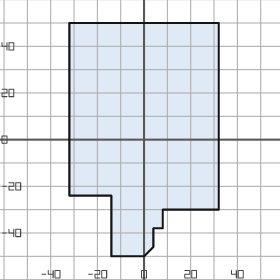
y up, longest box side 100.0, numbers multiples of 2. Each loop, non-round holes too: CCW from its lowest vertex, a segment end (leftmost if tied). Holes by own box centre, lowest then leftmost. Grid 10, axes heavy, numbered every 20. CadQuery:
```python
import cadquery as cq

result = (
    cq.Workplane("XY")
    .moveTo(-14.0, -50.0)
    .lineTo(0.0, -50.0)
    .lineTo(4.0, -46.0)
    .lineTo(4.0, -38.0)
    .lineTo(8.0, -38.0)
    .lineTo(8.0, -30.0)
    .lineTo(32.0, -30.0)
    .lineTo(32.0, 50.0)
    .lineTo(-32.0, 50.0)
    .lineTo(-32.0, -24.0)
    .lineTo(-14.0, -24.0)
    .close()
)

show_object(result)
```